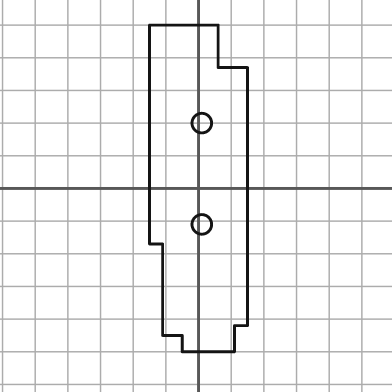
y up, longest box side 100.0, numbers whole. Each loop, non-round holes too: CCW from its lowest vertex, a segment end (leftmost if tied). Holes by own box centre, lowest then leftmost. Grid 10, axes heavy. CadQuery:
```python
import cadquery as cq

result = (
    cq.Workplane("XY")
    .moveTo(-5.0, -50.0)
    .lineTo(11.0, -50.0)
    .lineTo(11.0, -42.0)
    .lineTo(15.0, -42.0)
    .lineTo(15.0, 37.0)
    .lineTo(6.0, 37.0)
    .lineTo(6.0, 50.0)
    .lineTo(-15.0, 50.0)
    .lineTo(-15.0, -17.0)
    .lineTo(-11.0, -17.0)
    .lineTo(-11.0, -45.0)
    .lineTo(-5.0, -45.0)
    .close()
    .moveTo(1.0, -11.0)
    .circle(3.0)
    .moveTo(1.0, 20.0)
    .circle(3.0)
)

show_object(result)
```